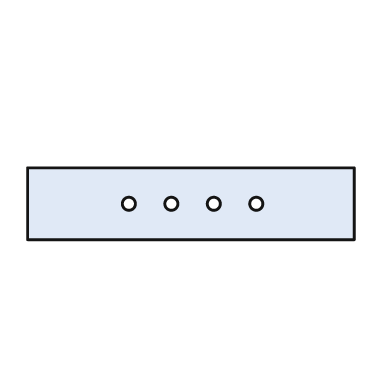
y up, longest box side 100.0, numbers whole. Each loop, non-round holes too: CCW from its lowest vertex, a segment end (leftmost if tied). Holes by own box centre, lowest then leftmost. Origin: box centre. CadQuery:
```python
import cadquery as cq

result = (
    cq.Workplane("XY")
    .moveTo(-50.0, -11.0)
    .lineTo(50.0, -11.0)
    .lineTo(50.0, 11.0)
    .lineTo(-50.0, 11.0)
    .close()
    .moveTo(-19.0, 0.0)
    .circle(2.0)
    .moveTo(-6.0, 0.0)
    .circle(2.0)
    .moveTo(7.0, 0.0)
    .circle(2.0)
    .moveTo(20.0, 0.0)
    .circle(2.0)
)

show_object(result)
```